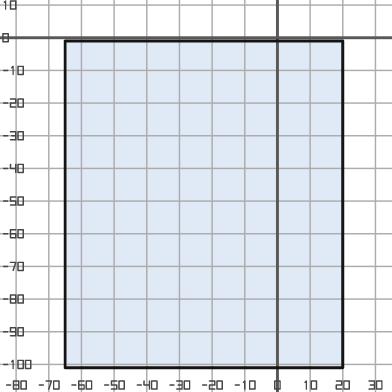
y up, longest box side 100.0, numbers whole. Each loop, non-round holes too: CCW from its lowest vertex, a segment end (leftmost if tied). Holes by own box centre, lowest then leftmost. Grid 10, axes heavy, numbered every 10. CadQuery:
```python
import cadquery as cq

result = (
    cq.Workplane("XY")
    .moveTo(-65.0, -101.0)
    .lineTo(20.0, -101.0)
    .lineTo(20.0, -1.0)
    .lineTo(-65.0, -1.0)
    .close()
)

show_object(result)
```